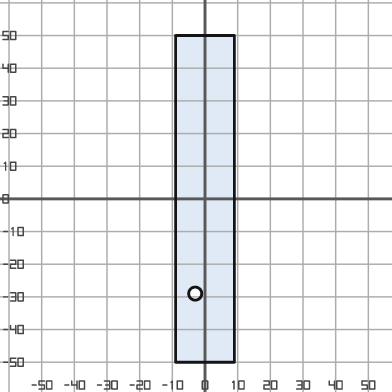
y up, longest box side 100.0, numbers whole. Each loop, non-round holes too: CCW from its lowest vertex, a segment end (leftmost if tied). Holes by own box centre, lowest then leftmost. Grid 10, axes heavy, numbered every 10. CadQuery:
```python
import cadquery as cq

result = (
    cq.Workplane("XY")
    .moveTo(-9.0, -50.0)
    .lineTo(9.0, -50.0)
    .lineTo(9.0, 50.0)
    .lineTo(-9.0, 50.0)
    .close()
    .moveTo(-3.0, -29.0)
    .circle(2.0)
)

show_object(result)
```